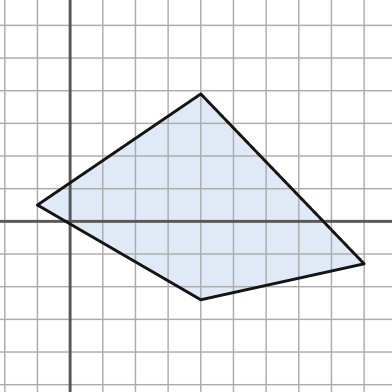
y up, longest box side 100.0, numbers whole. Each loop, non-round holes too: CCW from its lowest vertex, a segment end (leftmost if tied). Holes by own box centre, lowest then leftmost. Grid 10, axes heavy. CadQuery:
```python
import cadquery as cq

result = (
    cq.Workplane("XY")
    .moveTo(40.0, -24.0)
    .lineTo(90.0, -13.0)
    .lineTo(40.0, 39.0)
    .lineTo(-10.0, 5.0)
    .close()
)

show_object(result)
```